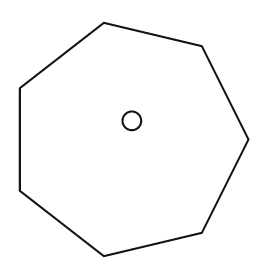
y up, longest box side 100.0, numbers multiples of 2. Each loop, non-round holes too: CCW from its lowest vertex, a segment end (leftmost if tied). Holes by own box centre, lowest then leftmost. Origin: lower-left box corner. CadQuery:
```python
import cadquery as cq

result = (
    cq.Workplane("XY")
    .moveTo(36.0, 0.0)
    .lineTo(78.0, 10.0)
    .lineTo(98.0, 50.0)
    .lineTo(78.0, 90.0)
    .lineTo(36.0, 100.0)
    .lineTo(0.0, 72.0)
    .lineTo(0.0, 28.0)
    .close()
    .moveTo(48.0, 58.0)
    .circle(4.0)
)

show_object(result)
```